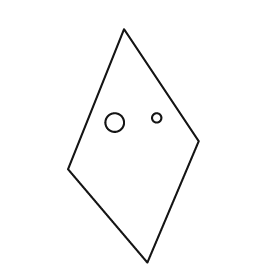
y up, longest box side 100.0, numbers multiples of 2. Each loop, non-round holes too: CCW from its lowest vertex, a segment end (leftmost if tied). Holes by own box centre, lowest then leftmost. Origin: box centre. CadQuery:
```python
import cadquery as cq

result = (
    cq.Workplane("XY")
    .moveTo(6.0, -50.0)
    .lineTo(28.0, 2.0)
    .lineTo(-4.0, 50.0)
    .lineTo(-28.0, -10.0)
    .close()
    .moveTo(-8.0, 10.0)
    .circle(4.0)
    .moveTo(10.0, 12.0)
    .circle(2.0)
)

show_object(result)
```